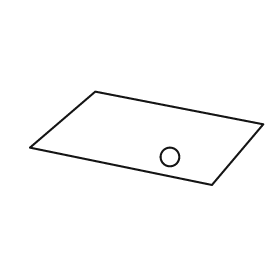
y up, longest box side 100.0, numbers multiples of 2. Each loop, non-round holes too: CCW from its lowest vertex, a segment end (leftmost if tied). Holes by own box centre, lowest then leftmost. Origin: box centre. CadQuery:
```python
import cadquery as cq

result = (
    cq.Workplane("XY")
    .moveTo(28.0, -20.0)
    .lineTo(50.0, 6.0)
    .lineTo(-22.0, 20.0)
    .lineTo(-50.0, -4.0)
    .close()
    .moveTo(10.0, -8.0)
    .circle(4.0)
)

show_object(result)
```